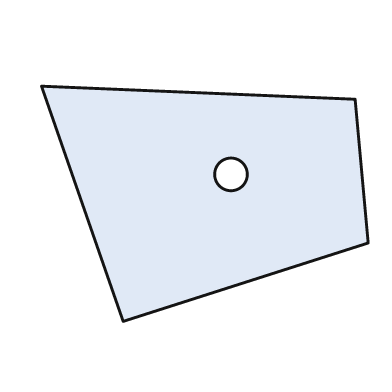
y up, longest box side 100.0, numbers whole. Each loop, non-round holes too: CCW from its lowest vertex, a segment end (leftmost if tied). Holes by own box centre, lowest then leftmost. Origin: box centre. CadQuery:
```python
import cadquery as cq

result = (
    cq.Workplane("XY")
    .moveTo(-25.0, -36.0)
    .lineTo(50.0, -12.0)
    .lineTo(46.0, 32.0)
    .lineTo(-50.0, 36.0)
    .close()
    .moveTo(8.0, 9.0)
    .circle(5.0)
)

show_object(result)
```